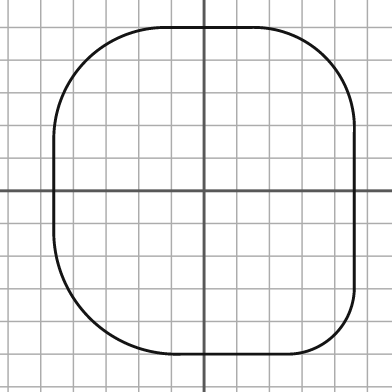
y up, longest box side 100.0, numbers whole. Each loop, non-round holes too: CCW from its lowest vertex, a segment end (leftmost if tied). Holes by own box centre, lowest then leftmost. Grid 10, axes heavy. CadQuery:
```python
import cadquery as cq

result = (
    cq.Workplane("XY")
    .moveTo(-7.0, -50.0)
    .lineTo(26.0, -50.0)
    .threePointArc((40.0, -44.0), (46.0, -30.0))
    .lineTo(46.0, 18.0)
    .threePointArc((37.0, 41.0), (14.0, 50.0))
    .lineTo(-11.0, 50.0)
    .threePointArc((-36.0, 40.0), (-46.0, 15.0))
    .lineTo(-46.0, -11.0)
    .threePointArc((-35.0, -39.0), (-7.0, -50.0))
    .close()
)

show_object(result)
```